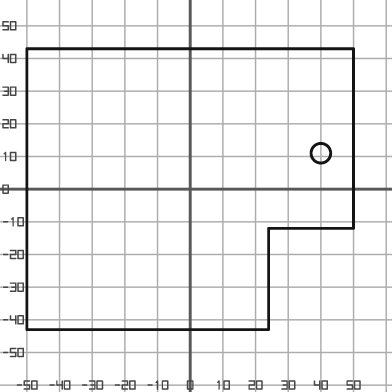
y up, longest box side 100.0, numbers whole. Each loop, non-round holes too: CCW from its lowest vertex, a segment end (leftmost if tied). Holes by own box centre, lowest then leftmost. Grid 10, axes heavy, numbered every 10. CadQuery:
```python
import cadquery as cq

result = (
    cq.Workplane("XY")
    .moveTo(-50.0, -43.0)
    .lineTo(24.0, -43.0)
    .lineTo(24.0, -12.0)
    .lineTo(50.0, -12.0)
    .lineTo(50.0, 43.0)
    .lineTo(-50.0, 43.0)
    .close()
    .moveTo(40.0, 11.0)
    .circle(3.0)
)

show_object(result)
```